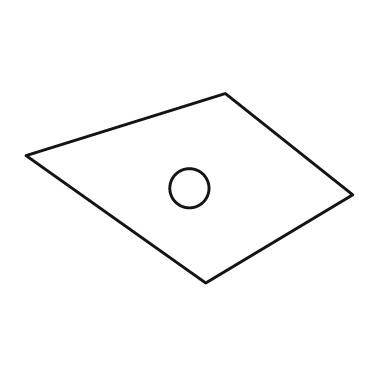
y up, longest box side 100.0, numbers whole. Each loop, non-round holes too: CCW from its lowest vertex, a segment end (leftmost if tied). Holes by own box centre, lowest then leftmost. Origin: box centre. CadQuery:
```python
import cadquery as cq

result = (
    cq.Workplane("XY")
    .moveTo(5.0, -29.0)
    .lineTo(50.0, -2.0)
    .lineTo(11.0, 29.0)
    .lineTo(-50.0, 10.0)
    .close()
    .moveTo(0.0, 0.0)
    .circle(6.0)
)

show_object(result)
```